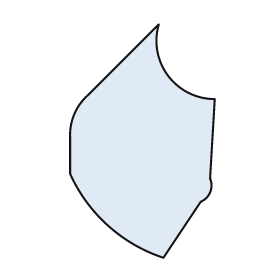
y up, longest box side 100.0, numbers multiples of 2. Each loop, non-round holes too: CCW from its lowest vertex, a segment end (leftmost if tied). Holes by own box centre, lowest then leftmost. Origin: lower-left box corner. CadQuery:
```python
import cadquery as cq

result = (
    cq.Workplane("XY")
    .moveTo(40.0, 0.0)
    .lineTo(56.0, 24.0)
    .threePointArc((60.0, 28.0), (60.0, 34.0))
    .lineTo(62.0, 68.0)
    .threePointArc((42.0, 78.0), (38.0, 100.0))
    .lineTo(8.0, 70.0)
    .threePointArc((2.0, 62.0), (0.0, 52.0))
    .lineTo(0.0, 36.0)
    .threePointArc((16.0, 14.0), (40.0, 0.0))
    .close()
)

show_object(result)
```